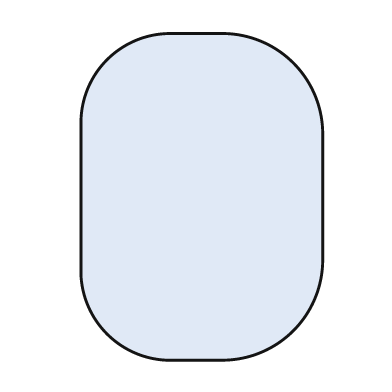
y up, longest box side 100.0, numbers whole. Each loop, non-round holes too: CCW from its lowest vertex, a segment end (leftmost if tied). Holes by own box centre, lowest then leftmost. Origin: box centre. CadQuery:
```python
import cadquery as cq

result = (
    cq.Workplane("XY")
    .moveTo(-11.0, -50.0)
    .lineTo(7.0, -50.0)
    .threePointArc((28.0, -41.0), (37.0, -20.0))
    .lineTo(37.0, 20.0)
    .threePointArc((28.0, 41.0), (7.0, 50.0))
    .lineTo(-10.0, 50.0)
    .threePointArc((-29.0, 42.0), (-37.0, 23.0))
    .lineTo(-37.0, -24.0)
    .threePointArc((-29.0, -42.0), (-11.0, -50.0))
    .close()
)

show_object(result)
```